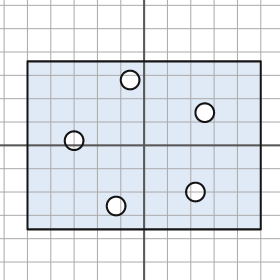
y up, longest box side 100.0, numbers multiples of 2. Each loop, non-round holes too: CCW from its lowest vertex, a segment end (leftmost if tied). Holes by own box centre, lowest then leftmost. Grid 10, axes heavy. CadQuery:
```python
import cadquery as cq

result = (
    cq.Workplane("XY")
    .moveTo(-50.0, -36.0)
    .lineTo(50.0, -36.0)
    .lineTo(50.0, 36.0)
    .lineTo(-50.0, 36.0)
    .close()
    .moveTo(-12.0, -26.0)
    .circle(4.0)
    .moveTo(22.0, -20.0)
    .circle(4.0)
    .moveTo(-30.0, 2.0)
    .circle(4.0)
    .moveTo(26.0, 14.0)
    .circle(4.0)
    .moveTo(-6.0, 28.0)
    .circle(4.0)
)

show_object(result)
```